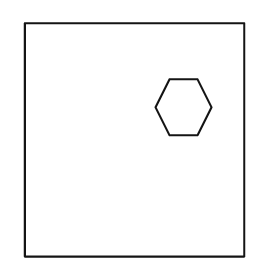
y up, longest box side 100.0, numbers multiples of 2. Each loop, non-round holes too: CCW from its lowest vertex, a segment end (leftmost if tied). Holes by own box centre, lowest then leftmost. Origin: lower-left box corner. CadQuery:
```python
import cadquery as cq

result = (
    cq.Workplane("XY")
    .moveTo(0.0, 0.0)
    .lineTo(94.0, 0.0)
    .lineTo(94.0, 100.0)
    .lineTo(0.0, 100.0)
    .close()
    .moveTo(62.0, 52.0)
    .lineTo(74.0, 52.0)
    .lineTo(80.0, 64.0)
    .lineTo(74.0, 76.0)
    .lineTo(62.0, 76.0)
    .lineTo(56.0, 64.0)
    .close()
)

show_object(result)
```